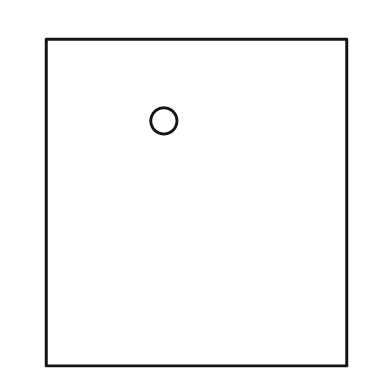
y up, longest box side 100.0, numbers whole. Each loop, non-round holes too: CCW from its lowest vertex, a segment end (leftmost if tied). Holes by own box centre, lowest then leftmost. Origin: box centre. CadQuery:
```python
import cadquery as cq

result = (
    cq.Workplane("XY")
    .moveTo(-46.0, -50.0)
    .lineTo(46.0, -50.0)
    .lineTo(46.0, 50.0)
    .lineTo(-46.0, 50.0)
    .close()
    .moveTo(-10.0, 25.0)
    .circle(4.0)
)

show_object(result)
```